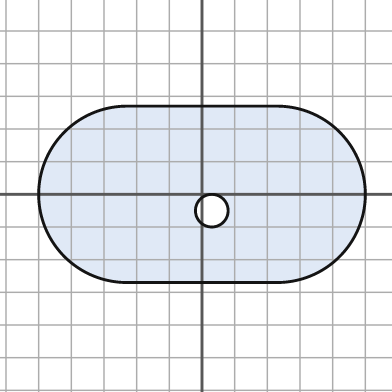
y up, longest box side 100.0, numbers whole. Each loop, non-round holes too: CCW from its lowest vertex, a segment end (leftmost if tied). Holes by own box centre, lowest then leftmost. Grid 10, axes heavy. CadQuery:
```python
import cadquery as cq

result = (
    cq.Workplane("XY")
    .moveTo(-23.0, -27.0)
    .lineTo(23.0, -27.0)
    .threePointArc((50.0, 0.0), (23.0, 27.0))
    .lineTo(-23.0, 27.0)
    .threePointArc((-50.0, 0.0), (-23.0, -27.0))
    .close()
    .moveTo(3.0, -5.0)
    .circle(5.0)
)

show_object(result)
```